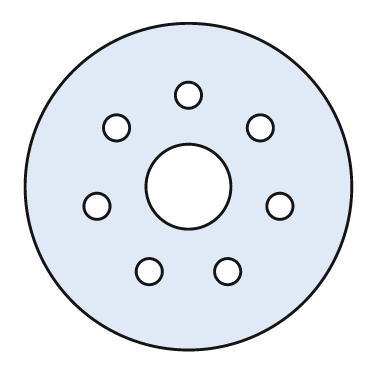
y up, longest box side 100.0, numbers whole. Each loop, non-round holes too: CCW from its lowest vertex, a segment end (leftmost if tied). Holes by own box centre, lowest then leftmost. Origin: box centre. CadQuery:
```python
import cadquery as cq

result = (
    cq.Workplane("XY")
    .moveTo(0.0, 0.0)
    .circle(50.0)
    .moveTo(-12.0, -26.0)
    .circle(4.0)
    .moveTo(12.0, -26.0)
    .circle(4.0)
    .moveTo(-28.0, -6.0)
    .circle(4.0)
    .moveTo(28.0, -6.0)
    .circle(4.0)
    .moveTo(0.0, 0.0)
    .circle(13.0)
    .moveTo(-22.0, 18.0)
    .circle(4.0)
    .moveTo(22.0, 18.0)
    .circle(4.0)
    .moveTo(0.0, 28.0)
    .circle(4.0)
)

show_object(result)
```